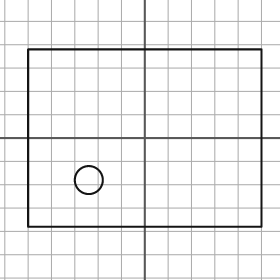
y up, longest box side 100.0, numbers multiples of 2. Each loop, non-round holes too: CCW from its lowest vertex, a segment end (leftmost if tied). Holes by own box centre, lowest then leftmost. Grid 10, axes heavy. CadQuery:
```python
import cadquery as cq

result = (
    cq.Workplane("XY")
    .moveTo(-50.0, -38.0)
    .lineTo(50.0, -38.0)
    .lineTo(50.0, 38.0)
    .lineTo(-50.0, 38.0)
    .close()
    .moveTo(-24.0, -18.0)
    .circle(6.0)
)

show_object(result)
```